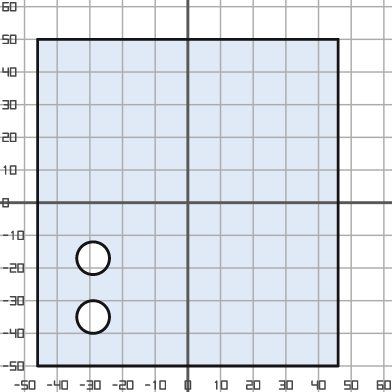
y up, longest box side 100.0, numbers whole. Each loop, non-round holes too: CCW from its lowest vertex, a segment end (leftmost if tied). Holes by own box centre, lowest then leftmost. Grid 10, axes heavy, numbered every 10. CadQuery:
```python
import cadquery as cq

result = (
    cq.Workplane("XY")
    .moveTo(-46.0, -50.0)
    .lineTo(46.0, -50.0)
    .lineTo(46.0, 50.0)
    .lineTo(-46.0, 50.0)
    .close()
    .moveTo(-29.0, -35.0)
    .circle(5.0)
    .moveTo(-29.0, -17.0)
    .circle(5.0)
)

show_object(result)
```